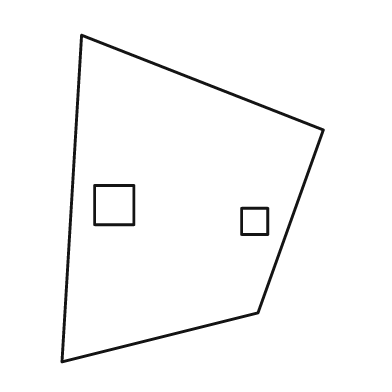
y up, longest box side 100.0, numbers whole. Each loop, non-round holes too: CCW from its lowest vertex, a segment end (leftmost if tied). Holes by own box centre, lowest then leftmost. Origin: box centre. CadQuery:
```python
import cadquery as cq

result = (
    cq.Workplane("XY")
    .moveTo(-40.0, -50.0)
    .lineTo(20.0, -35.0)
    .lineTo(40.0, 21.0)
    .lineTo(-34.0, 50.0)
    .close()
    .moveTo(15.0, -11.0)
    .lineTo(23.0, -11.0)
    .lineTo(23.0, -3.0)
    .lineTo(15.0, -3.0)
    .close()
    .moveTo(-30.0, -8.0)
    .lineTo(-18.0, -8.0)
    .lineTo(-18.0, 4.0)
    .lineTo(-30.0, 4.0)
    .close()
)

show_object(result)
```